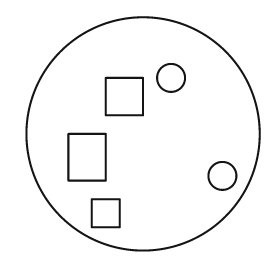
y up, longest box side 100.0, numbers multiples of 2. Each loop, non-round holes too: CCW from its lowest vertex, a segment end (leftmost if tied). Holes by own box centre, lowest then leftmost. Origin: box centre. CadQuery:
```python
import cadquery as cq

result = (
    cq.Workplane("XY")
    .moveTo(0.0, 0.0)
    .circle(50.0)
    .moveTo(-22.0, -40.0)
    .lineTo(-10.0, -40.0)
    .lineTo(-10.0, -28.0)
    .lineTo(-22.0, -28.0)
    .close()
    .moveTo(34.0, -18.0)
    .circle(6.0)
    .moveTo(-32.0, -20.0)
    .lineTo(-16.0, -20.0)
    .lineTo(-16.0, 0.0)
    .lineTo(-32.0, 0.0)
    .close()
    .moveTo(-16.0, 8.0)
    .lineTo(0.0, 8.0)
    .lineTo(0.0, 24.0)
    .lineTo(-16.0, 24.0)
    .close()
    .moveTo(12.0, 24.0)
    .circle(6.0)
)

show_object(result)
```